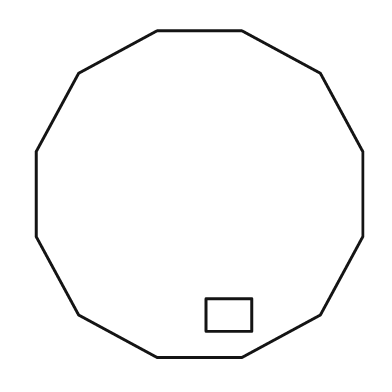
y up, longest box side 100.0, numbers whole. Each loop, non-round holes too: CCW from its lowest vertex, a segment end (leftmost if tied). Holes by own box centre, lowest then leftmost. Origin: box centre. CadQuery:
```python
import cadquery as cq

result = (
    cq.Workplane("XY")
    .moveTo(-13.0, -50.0)
    .lineTo(13.0, -50.0)
    .lineTo(37.0, -37.0)
    .lineTo(50.0, -13.0)
    .lineTo(50.0, 13.0)
    .lineTo(37.0, 37.0)
    .lineTo(13.0, 50.0)
    .lineTo(-13.0, 50.0)
    .lineTo(-37.0, 37.0)
    .lineTo(-50.0, 13.0)
    .lineTo(-50.0, -13.0)
    .lineTo(-37.0, -37.0)
    .close()
    .moveTo(2.0, -42.0)
    .lineTo(16.0, -42.0)
    .lineTo(16.0, -32.0)
    .lineTo(2.0, -32.0)
    .close()
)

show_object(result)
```